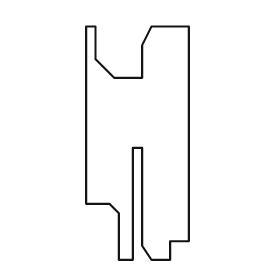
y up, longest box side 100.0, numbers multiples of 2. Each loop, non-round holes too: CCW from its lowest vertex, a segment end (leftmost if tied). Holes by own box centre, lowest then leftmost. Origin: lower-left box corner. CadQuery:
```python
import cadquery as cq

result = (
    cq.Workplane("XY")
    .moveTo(14.0, 0.0)
    .lineTo(20.0, 0.0)
    .lineTo(20.0, 48.0)
    .lineTo(24.0, 48.0)
    .lineTo(24.0, 6.0)
    .lineTo(28.0, 0.0)
    .lineTo(36.0, 0.0)
    .lineTo(36.0, 8.0)
    .lineTo(44.0, 8.0)
    .lineTo(44.0, 100.0)
    .lineTo(28.0, 100.0)
    .lineTo(24.0, 92.0)
    .lineTo(24.0, 78.0)
    .lineTo(12.0, 78.0)
    .lineTo(4.0, 86.0)
    .lineTo(4.0, 100.0)
    .lineTo(0.0, 100.0)
    .lineTo(0.0, 24.0)
    .lineTo(10.0, 24.0)
    .lineTo(14.0, 20.0)
    .close()
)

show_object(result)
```